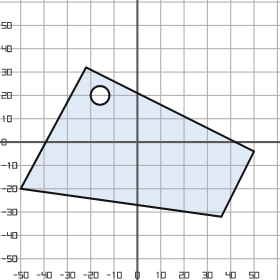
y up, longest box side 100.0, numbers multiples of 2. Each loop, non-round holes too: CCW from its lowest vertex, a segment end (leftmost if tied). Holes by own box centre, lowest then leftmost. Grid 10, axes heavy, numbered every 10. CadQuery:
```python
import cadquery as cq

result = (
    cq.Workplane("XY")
    .moveTo(36.0, -32.0)
    .lineTo(50.0, -4.0)
    .lineTo(-22.0, 32.0)
    .lineTo(-50.0, -20.0)
    .close()
    .moveTo(-16.0, 20.0)
    .circle(4.0)
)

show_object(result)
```